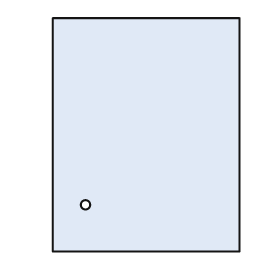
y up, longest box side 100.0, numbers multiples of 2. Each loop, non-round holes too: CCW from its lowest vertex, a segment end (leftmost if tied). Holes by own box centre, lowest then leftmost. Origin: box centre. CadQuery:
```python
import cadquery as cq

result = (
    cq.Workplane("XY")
    .moveTo(-40.0, -50.0)
    .lineTo(40.0, -50.0)
    .lineTo(40.0, 50.0)
    .lineTo(-40.0, 50.0)
    .close()
    .moveTo(-26.0, -30.0)
    .circle(2.0)
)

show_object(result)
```